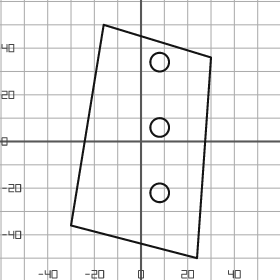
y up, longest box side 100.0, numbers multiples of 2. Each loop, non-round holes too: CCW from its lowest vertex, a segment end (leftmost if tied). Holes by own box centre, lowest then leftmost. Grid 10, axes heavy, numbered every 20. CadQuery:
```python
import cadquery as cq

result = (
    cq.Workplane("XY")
    .moveTo(24.0, -50.0)
    .lineTo(30.0, 36.0)
    .lineTo(-16.0, 50.0)
    .lineTo(-30.0, -36.0)
    .close()
    .moveTo(8.0, -22.0)
    .circle(4.0)
    .moveTo(8.0, 6.0)
    .circle(4.0)
    .moveTo(8.0, 34.0)
    .circle(4.0)
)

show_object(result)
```